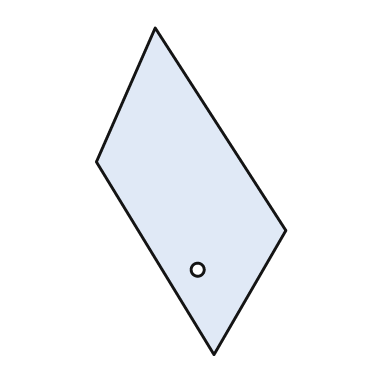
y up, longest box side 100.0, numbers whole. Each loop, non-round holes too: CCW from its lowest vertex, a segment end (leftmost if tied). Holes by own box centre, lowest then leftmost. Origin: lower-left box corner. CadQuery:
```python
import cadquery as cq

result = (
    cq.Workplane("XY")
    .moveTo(36.0, 0.0)
    .lineTo(58.0, 38.0)
    .lineTo(18.0, 100.0)
    .lineTo(0.0, 59.0)
    .close()
    .moveTo(31.0, 26.0)
    .circle(2.0)
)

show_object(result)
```